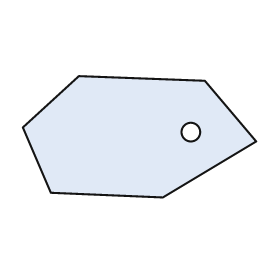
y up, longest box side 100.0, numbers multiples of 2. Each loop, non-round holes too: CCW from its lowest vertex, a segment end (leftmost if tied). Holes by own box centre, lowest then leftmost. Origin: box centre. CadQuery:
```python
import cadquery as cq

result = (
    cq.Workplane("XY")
    .moveTo(10.0, -26.0)
    .lineTo(50.0, -2.0)
    .lineTo(28.0, 24.0)
    .lineTo(-26.0, 26.0)
    .lineTo(-50.0, 4.0)
    .lineTo(-38.0, -24.0)
    .close()
    .moveTo(22.0, 2.0)
    .circle(4.0)
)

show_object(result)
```